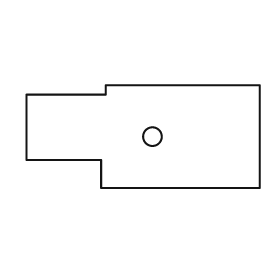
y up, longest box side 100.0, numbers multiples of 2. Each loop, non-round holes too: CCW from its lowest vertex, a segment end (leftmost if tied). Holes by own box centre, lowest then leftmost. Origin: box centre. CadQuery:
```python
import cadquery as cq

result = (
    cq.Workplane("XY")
    .moveTo(-18.0, -22.0)
    .lineTo(50.0, -22.0)
    .lineTo(50.0, 22.0)
    .lineTo(-16.0, 22.0)
    .lineTo(-16.0, 18.0)
    .lineTo(-50.0, 18.0)
    .lineTo(-50.0, -10.0)
    .lineTo(-18.0, -10.0)
    .close()
    .moveTo(4.0, 0.0)
    .circle(4.0)
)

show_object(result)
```